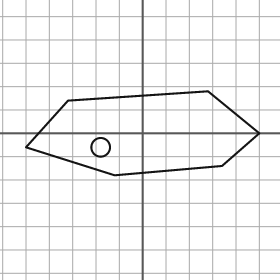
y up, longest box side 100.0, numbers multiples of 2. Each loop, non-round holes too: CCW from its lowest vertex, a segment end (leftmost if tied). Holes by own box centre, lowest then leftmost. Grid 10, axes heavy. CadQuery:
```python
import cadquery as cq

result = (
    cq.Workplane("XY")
    .moveTo(-12.0, -18.0)
    .lineTo(34.0, -14.0)
    .lineTo(50.0, 0.0)
    .lineTo(28.0, 18.0)
    .lineTo(-32.0, 14.0)
    .lineTo(-50.0, -6.0)
    .close()
    .moveTo(-18.0, -6.0)
    .circle(4.0)
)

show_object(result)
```